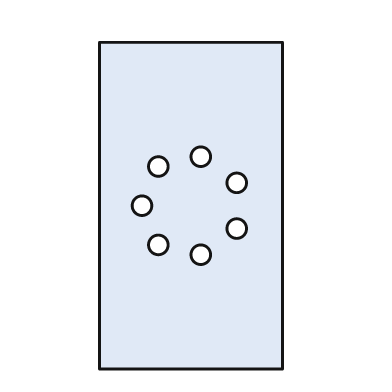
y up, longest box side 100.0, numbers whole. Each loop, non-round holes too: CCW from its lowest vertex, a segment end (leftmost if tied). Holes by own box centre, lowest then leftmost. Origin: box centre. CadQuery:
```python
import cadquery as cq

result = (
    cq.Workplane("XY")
    .moveTo(-28.0, -50.0)
    .lineTo(28.0, -50.0)
    .lineTo(28.0, 50.0)
    .lineTo(-28.0, 50.0)
    .close()
    .moveTo(3.0, -15.0)
    .circle(3.0)
    .moveTo(-10.0, -12.0)
    .circle(3.0)
    .moveTo(14.0, -7.0)
    .circle(3.0)
    .moveTo(-15.0, 0.0)
    .circle(3.0)
    .moveTo(14.0, 7.0)
    .circle(3.0)
    .moveTo(-10.0, 12.0)
    .circle(3.0)
    .moveTo(3.0, 15.0)
    .circle(3.0)
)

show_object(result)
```